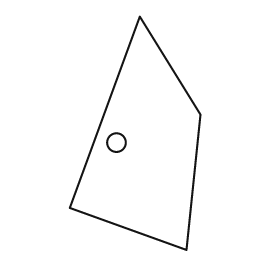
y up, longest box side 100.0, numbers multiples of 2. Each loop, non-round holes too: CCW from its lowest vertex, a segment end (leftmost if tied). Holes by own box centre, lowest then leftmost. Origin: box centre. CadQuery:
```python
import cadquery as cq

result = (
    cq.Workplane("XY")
    .moveTo(22.0, -50.0)
    .lineTo(28.0, 8.0)
    .lineTo(2.0, 50.0)
    .lineTo(-28.0, -32.0)
    .close()
    .moveTo(-8.0, -4.0)
    .circle(4.0)
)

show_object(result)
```